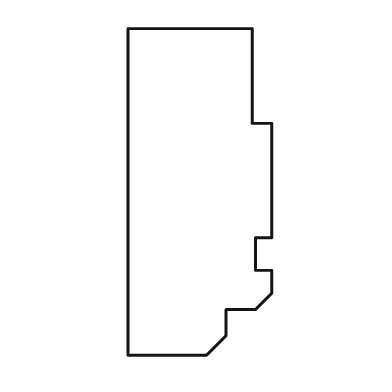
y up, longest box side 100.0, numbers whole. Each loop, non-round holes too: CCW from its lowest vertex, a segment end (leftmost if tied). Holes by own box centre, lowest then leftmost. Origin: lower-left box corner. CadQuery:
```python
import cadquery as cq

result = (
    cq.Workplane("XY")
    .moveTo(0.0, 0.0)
    .lineTo(24.0, 0.0)
    .lineTo(30.0, 6.0)
    .lineTo(30.0, 14.0)
    .lineTo(39.0, 14.0)
    .lineTo(44.0, 19.0)
    .lineTo(44.0, 26.0)
    .lineTo(39.0, 26.0)
    .lineTo(39.0, 36.0)
    .lineTo(44.0, 36.0)
    .lineTo(44.0, 71.0)
    .lineTo(38.0, 71.0)
    .lineTo(38.0, 100.0)
    .lineTo(0.0, 100.0)
    .close()
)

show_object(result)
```